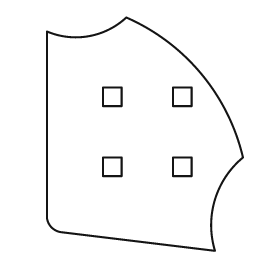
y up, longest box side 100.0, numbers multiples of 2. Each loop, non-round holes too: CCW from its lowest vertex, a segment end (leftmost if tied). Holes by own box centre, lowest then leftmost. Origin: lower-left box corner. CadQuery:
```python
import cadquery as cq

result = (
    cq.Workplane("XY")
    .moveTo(72.0, 0.0)
    .threePointArc((72.0, 22.0), (84.0, 40.0))
    .threePointArc((66.0, 76.0), (34.0, 100.0))
    .threePointArc((18.0, 92.0), (0.0, 94.0))
    .lineTo(0.0, 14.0)
    .threePointArc((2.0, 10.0), (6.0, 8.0))
    .close()
    .moveTo(24.0, 32.0)
    .lineTo(32.0, 32.0)
    .lineTo(32.0, 40.0)
    .lineTo(24.0, 40.0)
    .close()
    .moveTo(54.0, 32.0)
    .lineTo(62.0, 32.0)
    .lineTo(62.0, 40.0)
    .lineTo(54.0, 40.0)
    .close()
    .moveTo(24.0, 62.0)
    .lineTo(32.0, 62.0)
    .lineTo(32.0, 70.0)
    .lineTo(24.0, 70.0)
    .close()
    .moveTo(54.0, 62.0)
    .lineTo(62.0, 62.0)
    .lineTo(62.0, 70.0)
    .lineTo(54.0, 70.0)
    .close()
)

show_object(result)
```